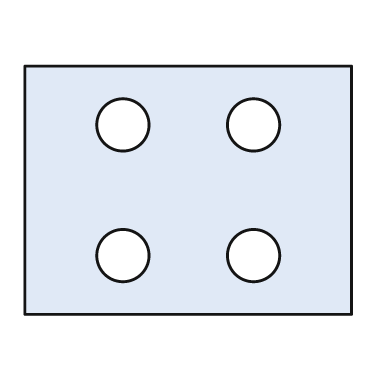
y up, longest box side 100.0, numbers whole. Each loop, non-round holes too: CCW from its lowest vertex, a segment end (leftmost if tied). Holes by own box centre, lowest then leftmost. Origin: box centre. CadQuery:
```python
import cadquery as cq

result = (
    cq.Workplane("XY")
    .moveTo(-50.0, -38.0)
    .lineTo(50.0, -38.0)
    .lineTo(50.0, 38.0)
    .lineTo(-50.0, 38.0)
    .close()
    .moveTo(-20.0, -20.0)
    .circle(8.0)
    .moveTo(20.0, -20.0)
    .circle(8.0)
    .moveTo(-20.0, 20.0)
    .circle(8.0)
    .moveTo(20.0, 20.0)
    .circle(8.0)
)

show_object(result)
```